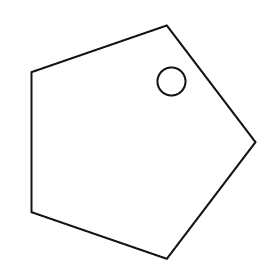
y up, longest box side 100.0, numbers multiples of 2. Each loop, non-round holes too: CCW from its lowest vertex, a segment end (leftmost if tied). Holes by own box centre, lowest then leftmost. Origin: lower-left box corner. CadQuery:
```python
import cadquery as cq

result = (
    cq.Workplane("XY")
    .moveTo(58.0, 0.0)
    .lineTo(96.0, 50.0)
    .lineTo(58.0, 100.0)
    .lineTo(0.0, 80.0)
    .lineTo(0.0, 20.0)
    .close()
    .moveTo(60.0, 76.0)
    .circle(6.0)
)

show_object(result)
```